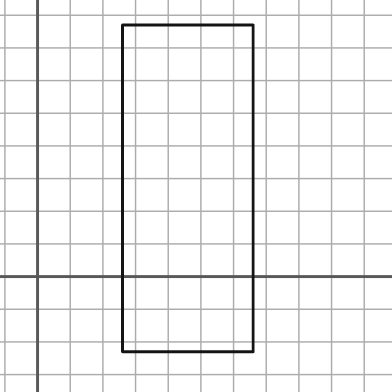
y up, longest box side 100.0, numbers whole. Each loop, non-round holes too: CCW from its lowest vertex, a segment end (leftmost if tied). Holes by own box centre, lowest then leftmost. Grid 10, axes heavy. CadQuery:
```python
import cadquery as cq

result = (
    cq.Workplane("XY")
    .moveTo(26.0, -23.0)
    .lineTo(66.0, -23.0)
    .lineTo(66.0, 77.0)
    .lineTo(26.0, 77.0)
    .close()
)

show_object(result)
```